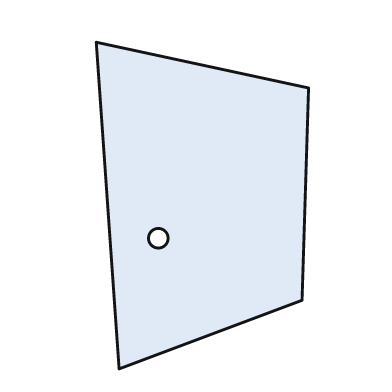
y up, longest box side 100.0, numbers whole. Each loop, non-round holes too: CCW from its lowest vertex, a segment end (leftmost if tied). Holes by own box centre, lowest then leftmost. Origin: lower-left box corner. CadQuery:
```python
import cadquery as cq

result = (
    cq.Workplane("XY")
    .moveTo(7.0, 0.0)
    .lineTo(63.0, 21.0)
    .lineTo(65.0, 86.0)
    .lineTo(0.0, 100.0)
    .close()
    .moveTo(19.0, 40.0)
    .circle(3.0)
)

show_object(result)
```